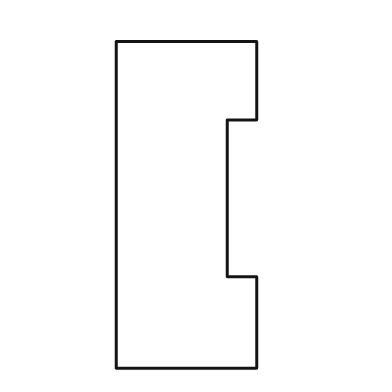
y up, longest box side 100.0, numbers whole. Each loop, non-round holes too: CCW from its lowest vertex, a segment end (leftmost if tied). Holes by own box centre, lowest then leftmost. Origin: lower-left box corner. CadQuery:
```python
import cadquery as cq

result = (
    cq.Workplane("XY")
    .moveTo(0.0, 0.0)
    .lineTo(43.0, 0.0)
    .lineTo(43.0, 28.0)
    .lineTo(34.0, 28.0)
    .lineTo(34.0, 76.0)
    .lineTo(43.0, 76.0)
    .lineTo(43.0, 100.0)
    .lineTo(0.0, 100.0)
    .close()
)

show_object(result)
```